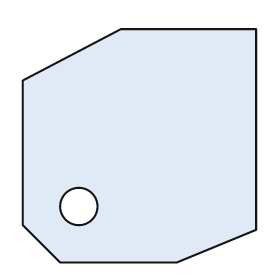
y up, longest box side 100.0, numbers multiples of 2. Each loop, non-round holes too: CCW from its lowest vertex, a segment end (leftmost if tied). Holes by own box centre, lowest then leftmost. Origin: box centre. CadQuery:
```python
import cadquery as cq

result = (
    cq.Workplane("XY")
    .moveTo(-34.0, -50.0)
    .lineTo(16.0, -50.0)
    .lineTo(50.0, -36.0)
    .lineTo(50.0, 50.0)
    .lineTo(-8.0, 50.0)
    .lineTo(-50.0, 28.0)
    .lineTo(-50.0, -34.0)
    .close()
    .moveTo(-26.0, -26.0)
    .circle(8.0)
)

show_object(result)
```